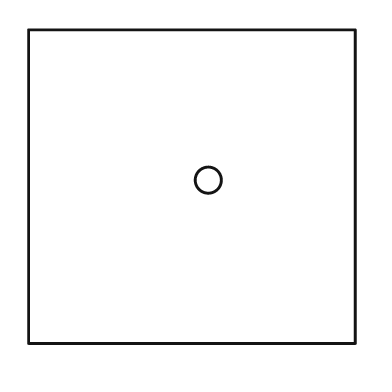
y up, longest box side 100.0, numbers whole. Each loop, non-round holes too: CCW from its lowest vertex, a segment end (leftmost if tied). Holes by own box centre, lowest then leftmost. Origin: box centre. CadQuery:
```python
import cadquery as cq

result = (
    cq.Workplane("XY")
    .moveTo(-50.0, -48.0)
    .lineTo(50.0, -48.0)
    .lineTo(50.0, 48.0)
    .lineTo(-50.0, 48.0)
    .close()
    .moveTo(5.0, 2.0)
    .circle(4.0)
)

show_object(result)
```